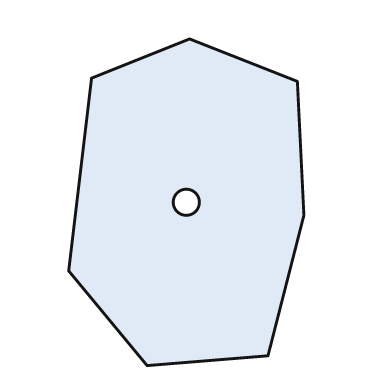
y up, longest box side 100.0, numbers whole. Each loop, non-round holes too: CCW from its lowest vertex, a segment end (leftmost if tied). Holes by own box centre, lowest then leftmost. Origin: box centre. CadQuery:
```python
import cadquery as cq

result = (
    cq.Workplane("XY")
    .moveTo(-12.0, -50.0)
    .lineTo(25.0, -47.0)
    .lineTo(36.0, -4.0)
    .lineTo(34.0, 37.0)
    .lineTo(1.0, 50.0)
    .lineTo(-29.0, 38.0)
    .lineTo(-36.0, -21.0)
    .close()
    .moveTo(0.0, 0.0)
    .circle(4.0)
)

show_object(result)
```